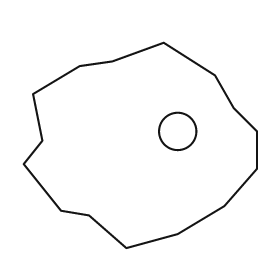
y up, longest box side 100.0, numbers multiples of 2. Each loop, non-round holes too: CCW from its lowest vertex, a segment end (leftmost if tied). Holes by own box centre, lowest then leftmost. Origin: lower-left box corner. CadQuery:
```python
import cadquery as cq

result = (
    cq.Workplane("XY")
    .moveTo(44.0, 0.0)
    .lineTo(66.0, 6.0)
    .lineTo(86.0, 18.0)
    .lineTo(100.0, 34.0)
    .lineTo(100.0, 50.0)
    .lineTo(90.0, 60.0)
    .lineTo(82.0, 74.0)
    .lineTo(60.0, 88.0)
    .lineTo(38.0, 80.0)
    .lineTo(24.0, 78.0)
    .lineTo(4.0, 66.0)
    .lineTo(8.0, 46.0)
    .lineTo(0.0, 36.0)
    .lineTo(16.0, 16.0)
    .lineTo(28.0, 14.0)
    .close()
    .moveTo(66.0, 50.0)
    .circle(8.0)
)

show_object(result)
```